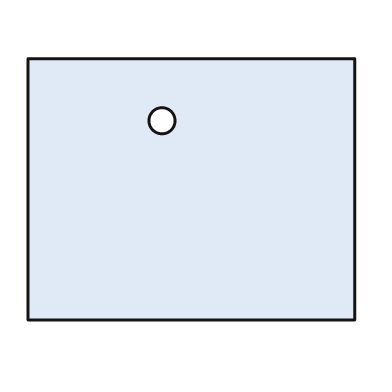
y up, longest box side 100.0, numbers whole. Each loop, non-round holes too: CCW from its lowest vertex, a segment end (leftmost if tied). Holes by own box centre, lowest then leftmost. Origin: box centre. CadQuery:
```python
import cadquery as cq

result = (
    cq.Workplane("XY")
    .moveTo(-50.0, -40.0)
    .lineTo(50.0, -40.0)
    .lineTo(50.0, 40.0)
    .lineTo(-50.0, 40.0)
    .close()
    .moveTo(-9.0, 21.0)
    .circle(4.0)
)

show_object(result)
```